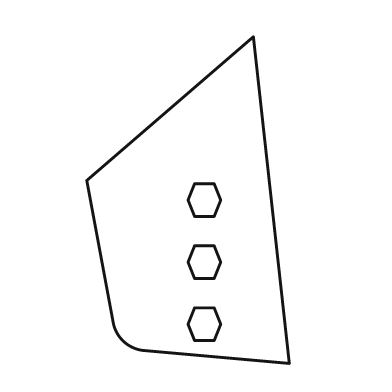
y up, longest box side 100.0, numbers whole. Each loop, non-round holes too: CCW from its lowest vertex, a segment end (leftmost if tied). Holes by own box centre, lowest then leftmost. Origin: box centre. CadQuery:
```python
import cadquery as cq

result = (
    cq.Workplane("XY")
    .moveTo(31.0, -50.0)
    .lineTo(20.0, 50.0)
    .lineTo(-31.0, 6.0)
    .lineTo(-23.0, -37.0)
    .threePointArc((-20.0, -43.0), (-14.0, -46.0))
    .close()
    .moveTo(2.0, -43.0)
    .lineTo(8.0, -43.0)
    .lineTo(10.0, -38.0)
    .lineTo(8.0, -33.0)
    .lineTo(2.0, -33.0)
    .lineTo(0.0, -38.0)
    .close()
    .moveTo(2.0, -24.0)
    .lineTo(8.0, -24.0)
    .lineTo(10.0, -19.0)
    .lineTo(8.0, -14.0)
    .lineTo(2.0, -14.0)
    .lineTo(0.0, -19.0)
    .close()
    .moveTo(2.0, -5.0)
    .lineTo(8.0, -5.0)
    .lineTo(10.0, 0.0)
    .lineTo(8.0, 5.0)
    .lineTo(2.0, 5.0)
    .lineTo(0.0, 0.0)
    .close()
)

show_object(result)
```